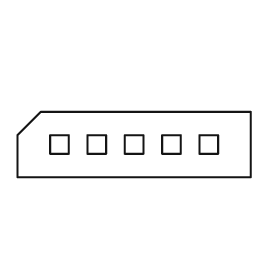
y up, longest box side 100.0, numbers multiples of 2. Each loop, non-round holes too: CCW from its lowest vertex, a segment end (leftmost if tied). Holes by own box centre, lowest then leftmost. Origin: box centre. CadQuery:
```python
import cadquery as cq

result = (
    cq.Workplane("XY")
    .moveTo(-50.0, -14.0)
    .lineTo(50.0, -14.0)
    .lineTo(50.0, 14.0)
    .lineTo(-40.0, 14.0)
    .lineTo(-50.0, 4.0)
    .close()
    .moveTo(-36.0, -4.0)
    .lineTo(-28.0, -4.0)
    .lineTo(-28.0, 4.0)
    .lineTo(-36.0, 4.0)
    .close()
    .moveTo(-20.0, -4.0)
    .lineTo(-12.0, -4.0)
    .lineTo(-12.0, 4.0)
    .lineTo(-20.0, 4.0)
    .close()
    .moveTo(-4.0, -4.0)
    .lineTo(4.0, -4.0)
    .lineTo(4.0, 4.0)
    .lineTo(-4.0, 4.0)
    .close()
    .moveTo(12.0, -4.0)
    .lineTo(20.0, -4.0)
    .lineTo(20.0, 4.0)
    .lineTo(12.0, 4.0)
    .close()
    .moveTo(28.0, -4.0)
    .lineTo(36.0, -4.0)
    .lineTo(36.0, 4.0)
    .lineTo(28.0, 4.0)
    .close()
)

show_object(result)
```